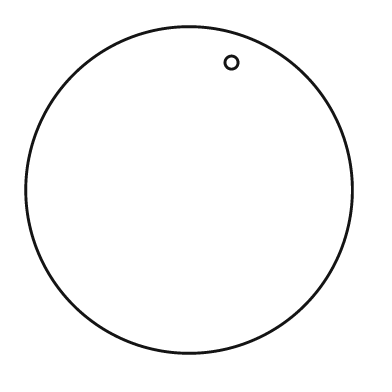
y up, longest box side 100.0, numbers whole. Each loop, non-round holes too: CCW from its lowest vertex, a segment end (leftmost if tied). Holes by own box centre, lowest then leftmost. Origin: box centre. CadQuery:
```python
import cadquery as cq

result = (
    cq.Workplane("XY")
    .moveTo(0.0, 0.0)
    .circle(50.0)
    .moveTo(13.0, 39.0)
    .circle(2.0)
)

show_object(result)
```